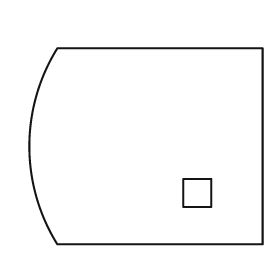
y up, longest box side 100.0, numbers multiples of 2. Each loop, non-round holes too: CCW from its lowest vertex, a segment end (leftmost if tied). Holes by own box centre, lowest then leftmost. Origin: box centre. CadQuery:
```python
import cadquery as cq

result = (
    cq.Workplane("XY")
    .moveTo(-38.0, -42.0)
    .lineTo(50.0, -42.0)
    .lineTo(50.0, 42.0)
    .lineTo(-38.0, 42.0)
    .threePointArc((-50.0, 0.0), (-38.0, -42.0))
    .close()
    .moveTo(16.0, -26.0)
    .lineTo(28.0, -26.0)
    .lineTo(28.0, -14.0)
    .lineTo(16.0, -14.0)
    .close()
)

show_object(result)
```